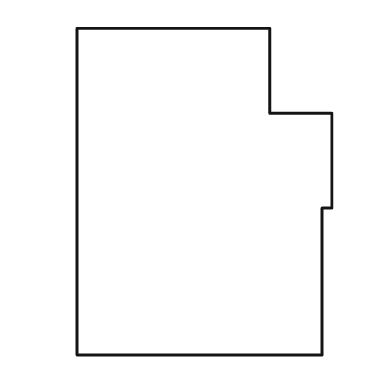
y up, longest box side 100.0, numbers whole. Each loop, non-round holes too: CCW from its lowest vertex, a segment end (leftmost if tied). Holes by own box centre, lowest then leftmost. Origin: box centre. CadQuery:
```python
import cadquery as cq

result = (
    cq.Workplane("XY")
    .moveTo(-39.0, -50.0)
    .lineTo(36.0, -50.0)
    .lineTo(36.0, -5.0)
    .lineTo(39.0, -5.0)
    .lineTo(39.0, 24.0)
    .lineTo(20.0, 24.0)
    .lineTo(20.0, 50.0)
    .lineTo(-39.0, 50.0)
    .close()
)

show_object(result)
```